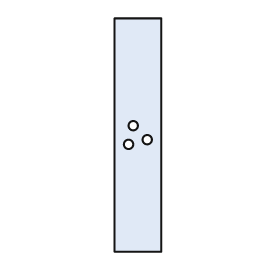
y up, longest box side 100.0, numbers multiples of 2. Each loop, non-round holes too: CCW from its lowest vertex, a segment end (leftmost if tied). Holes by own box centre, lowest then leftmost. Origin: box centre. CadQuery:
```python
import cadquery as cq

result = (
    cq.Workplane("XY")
    .moveTo(-10.0, -50.0)
    .lineTo(10.0, -50.0)
    .lineTo(10.0, 50.0)
    .lineTo(-10.0, 50.0)
    .close()
    .moveTo(-4.0, -4.0)
    .circle(2.0)
    .moveTo(4.0, -2.0)
    .circle(2.0)
    .moveTo(-2.0, 4.0)
    .circle(2.0)
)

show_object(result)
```